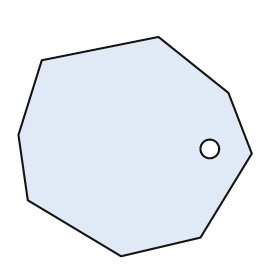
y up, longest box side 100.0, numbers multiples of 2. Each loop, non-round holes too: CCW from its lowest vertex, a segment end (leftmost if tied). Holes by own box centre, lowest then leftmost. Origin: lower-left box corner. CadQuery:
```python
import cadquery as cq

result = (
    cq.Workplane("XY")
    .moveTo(44.0, 0.0)
    .lineTo(78.0, 8.0)
    .lineTo(100.0, 44.0)
    .lineTo(90.0, 70.0)
    .lineTo(60.0, 94.0)
    .lineTo(10.0, 84.0)
    .lineTo(0.0, 52.0)
    .lineTo(4.0, 24.0)
    .close()
    .moveTo(82.0, 46.0)
    .circle(4.0)
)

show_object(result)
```